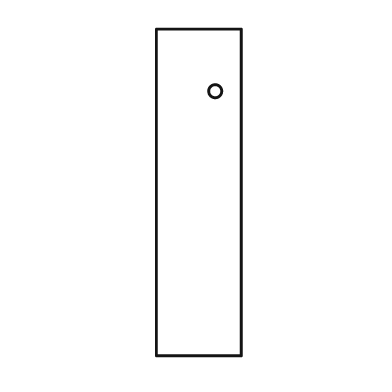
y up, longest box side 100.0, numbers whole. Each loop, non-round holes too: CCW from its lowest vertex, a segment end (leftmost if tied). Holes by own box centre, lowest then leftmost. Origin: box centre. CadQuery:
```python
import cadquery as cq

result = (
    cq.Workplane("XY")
    .moveTo(-13.0, -50.0)
    .lineTo(13.0, -50.0)
    .lineTo(13.0, 50.0)
    .lineTo(-13.0, 50.0)
    .close()
    .moveTo(5.0, 31.0)
    .circle(2.0)
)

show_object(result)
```